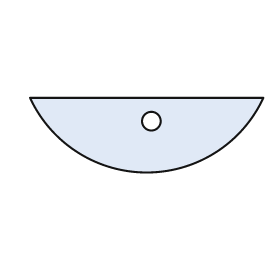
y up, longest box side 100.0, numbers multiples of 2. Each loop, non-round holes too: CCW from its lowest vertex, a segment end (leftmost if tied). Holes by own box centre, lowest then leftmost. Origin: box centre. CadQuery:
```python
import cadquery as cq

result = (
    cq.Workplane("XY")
    .moveTo(-50.0, 16.0)
    .threePointArc((0.0, -16.0), (50.0, 16.0))
    .close()
    .moveTo(2.0, 6.0)
    .circle(4.0)
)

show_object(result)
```